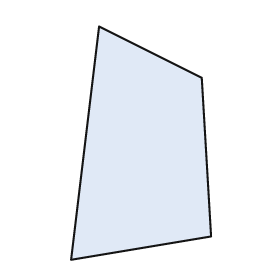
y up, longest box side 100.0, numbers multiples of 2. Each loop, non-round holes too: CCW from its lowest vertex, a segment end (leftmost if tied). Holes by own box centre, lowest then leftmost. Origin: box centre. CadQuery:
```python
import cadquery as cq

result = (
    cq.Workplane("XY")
    .moveTo(-30.0, -50.0)
    .lineTo(30.0, -40.0)
    .lineTo(26.0, 28.0)
    .lineTo(-18.0, 50.0)
    .close()
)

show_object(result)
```